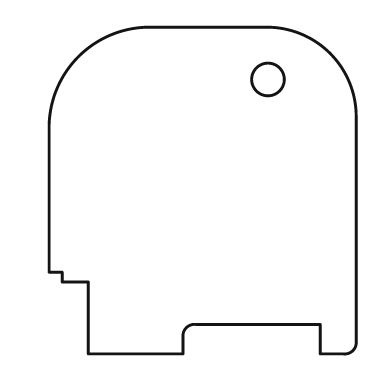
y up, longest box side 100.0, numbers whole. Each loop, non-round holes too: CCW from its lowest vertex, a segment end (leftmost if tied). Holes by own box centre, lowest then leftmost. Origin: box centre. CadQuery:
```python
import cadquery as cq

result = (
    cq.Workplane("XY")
    .moveTo(-35.0, -50.0)
    .lineTo(-6.0, -50.0)
    .lineTo(-6.0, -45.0)
    .threePointArc((-5.0, -42.0), (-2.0, -41.0))
    .lineTo(36.0, -41.0)
    .lineTo(36.0, -50.0)
    .lineTo(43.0, -50.0)
    .threePointArc((46.0, -49.0), (47.0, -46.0))
    .lineTo(47.0, 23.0)
    .threePointArc((39.0, 42.0), (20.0, 50.0))
    .lineTo(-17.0, 50.0)
    .threePointArc((-38.0, 41.0), (-47.0, 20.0))
    .lineTo(-47.0, -25.0)
    .lineTo(-43.0, -25.0)
    .lineTo(-43.0, -28.0)
    .lineTo(-35.0, -28.0)
    .close()
    .moveTo(20.0, 34.0)
    .circle(5.0)
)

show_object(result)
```